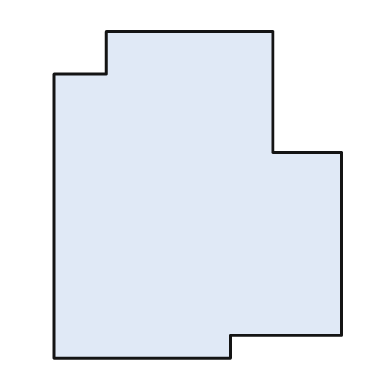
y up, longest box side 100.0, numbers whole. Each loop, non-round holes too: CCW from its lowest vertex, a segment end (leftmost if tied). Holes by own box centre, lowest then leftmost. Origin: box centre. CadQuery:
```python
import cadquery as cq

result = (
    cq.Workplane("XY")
    .moveTo(-44.0, -50.0)
    .lineTo(10.0, -50.0)
    .lineTo(10.0, -43.0)
    .lineTo(44.0, -43.0)
    .lineTo(44.0, 13.0)
    .lineTo(23.0, 13.0)
    .lineTo(23.0, 50.0)
    .lineTo(-28.0, 50.0)
    .lineTo(-28.0, 37.0)
    .lineTo(-44.0, 37.0)
    .close()
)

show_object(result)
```